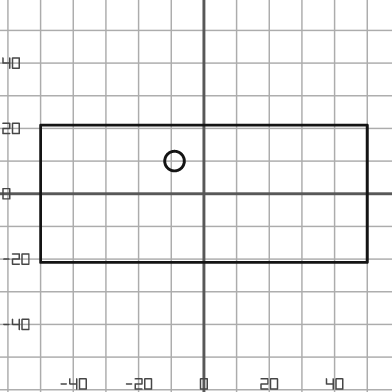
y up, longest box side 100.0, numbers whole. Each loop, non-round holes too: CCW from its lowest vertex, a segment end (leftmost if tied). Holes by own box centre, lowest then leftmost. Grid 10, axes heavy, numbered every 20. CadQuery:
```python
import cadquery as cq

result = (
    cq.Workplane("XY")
    .moveTo(-50.0, -21.0)
    .lineTo(50.0, -21.0)
    .lineTo(50.0, 21.0)
    .lineTo(-50.0, 21.0)
    .close()
    .moveTo(-9.0, 10.0)
    .circle(3.0)
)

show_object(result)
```